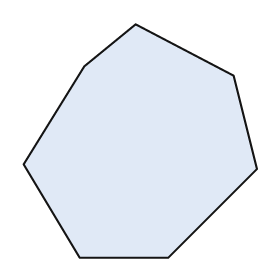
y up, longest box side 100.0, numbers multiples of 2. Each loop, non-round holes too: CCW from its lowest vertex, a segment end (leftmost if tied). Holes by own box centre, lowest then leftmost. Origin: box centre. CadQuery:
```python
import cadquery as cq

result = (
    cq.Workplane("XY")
    .moveTo(-26.0, -50.0)
    .lineTo(12.0, -50.0)
    .lineTo(50.0, -12.0)
    .lineTo(40.0, 28.0)
    .lineTo(-2.0, 50.0)
    .lineTo(-24.0, 32.0)
    .lineTo(-50.0, -10.0)
    .close()
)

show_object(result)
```